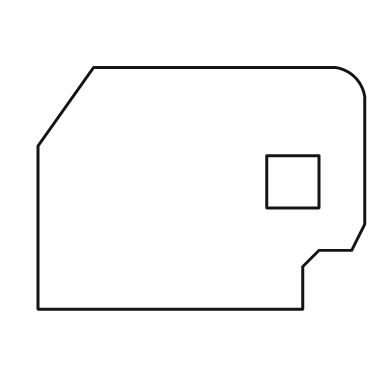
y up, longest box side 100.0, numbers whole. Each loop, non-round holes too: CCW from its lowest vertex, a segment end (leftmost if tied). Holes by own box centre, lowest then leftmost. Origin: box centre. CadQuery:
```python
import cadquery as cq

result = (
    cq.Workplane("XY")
    .moveTo(-50.0, -37.0)
    .lineTo(31.0, -37.0)
    .lineTo(31.0, -24.0)
    .lineTo(36.0, -19.0)
    .lineTo(46.0, -19.0)
    .lineTo(50.0, -11.0)
    .lineTo(50.0, 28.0)
    .threePointArc((47.0, 34.0), (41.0, 37.0))
    .lineTo(-33.0, 37.0)
    .lineTo(-50.0, 13.0)
    .close()
    .moveTo(20.0, -6.0)
    .lineTo(36.0, -6.0)
    .lineTo(36.0, 10.0)
    .lineTo(20.0, 10.0)
    .close()
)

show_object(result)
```